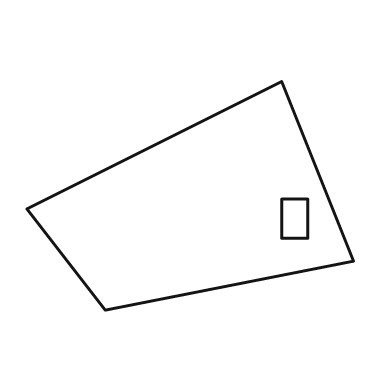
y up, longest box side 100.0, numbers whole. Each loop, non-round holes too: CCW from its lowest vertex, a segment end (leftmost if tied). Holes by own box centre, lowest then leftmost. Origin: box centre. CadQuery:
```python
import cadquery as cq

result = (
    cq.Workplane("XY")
    .moveTo(-26.0, -35.0)
    .lineTo(50.0, -20.0)
    .lineTo(28.0, 35.0)
    .lineTo(-50.0, -4.0)
    .close()
    .moveTo(28.0, -13.0)
    .lineTo(36.0, -13.0)
    .lineTo(36.0, -1.0)
    .lineTo(28.0, -1.0)
    .close()
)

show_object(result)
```